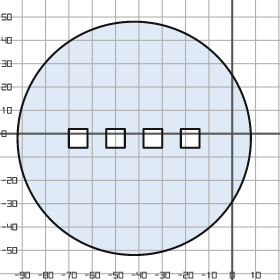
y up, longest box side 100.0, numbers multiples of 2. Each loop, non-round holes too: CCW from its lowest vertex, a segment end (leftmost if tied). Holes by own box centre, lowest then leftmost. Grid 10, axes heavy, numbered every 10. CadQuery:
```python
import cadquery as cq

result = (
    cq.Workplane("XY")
    .moveTo(-42.0, -2.0)
    .circle(50.0)
    .moveTo(-70.0, -6.0)
    .lineTo(-62.0, -6.0)
    .lineTo(-62.0, 2.0)
    .lineTo(-70.0, 2.0)
    .close()
    .moveTo(-54.0, -6.0)
    .lineTo(-46.0, -6.0)
    .lineTo(-46.0, 2.0)
    .lineTo(-54.0, 2.0)
    .close()
    .moveTo(-38.0, -6.0)
    .lineTo(-30.0, -6.0)
    .lineTo(-30.0, 2.0)
    .lineTo(-38.0, 2.0)
    .close()
    .moveTo(-22.0, -6.0)
    .lineTo(-14.0, -6.0)
    .lineTo(-14.0, 2.0)
    .lineTo(-22.0, 2.0)
    .close()
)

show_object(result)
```